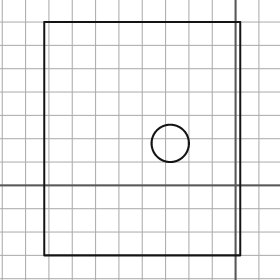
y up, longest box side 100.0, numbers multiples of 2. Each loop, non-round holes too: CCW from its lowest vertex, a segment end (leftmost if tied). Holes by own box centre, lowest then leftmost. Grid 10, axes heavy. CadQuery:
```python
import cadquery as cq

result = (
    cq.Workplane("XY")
    .moveTo(-82.0, -30.0)
    .lineTo(2.0, -30.0)
    .lineTo(2.0, 70.0)
    .lineTo(-82.0, 70.0)
    .close()
    .moveTo(-28.0, 18.0)
    .circle(8.0)
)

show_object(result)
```